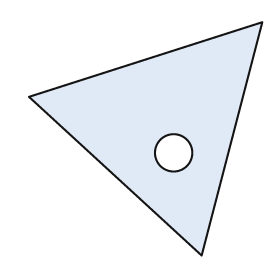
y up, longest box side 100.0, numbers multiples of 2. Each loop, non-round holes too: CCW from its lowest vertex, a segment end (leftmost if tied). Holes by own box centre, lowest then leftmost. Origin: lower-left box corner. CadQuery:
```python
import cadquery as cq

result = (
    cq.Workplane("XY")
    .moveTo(74.0, 0.0)
    .lineTo(100.0, 100.0)
    .lineTo(0.0, 68.0)
    .close()
    .moveTo(62.0, 44.0)
    .circle(8.0)
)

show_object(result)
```